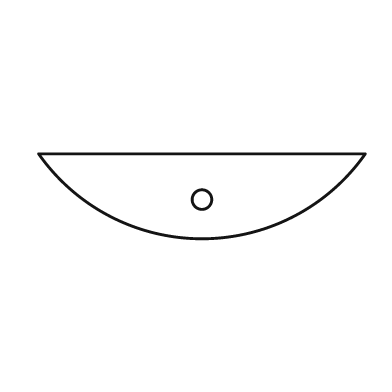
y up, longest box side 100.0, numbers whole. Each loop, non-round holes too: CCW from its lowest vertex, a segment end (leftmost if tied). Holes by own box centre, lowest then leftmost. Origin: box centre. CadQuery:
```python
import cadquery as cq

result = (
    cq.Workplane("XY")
    .moveTo(-50.0, 13.0)
    .threePointArc((0.0, -13.0), (50.0, 13.0))
    .close()
    .moveTo(0.0, -1.0)
    .circle(3.0)
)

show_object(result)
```